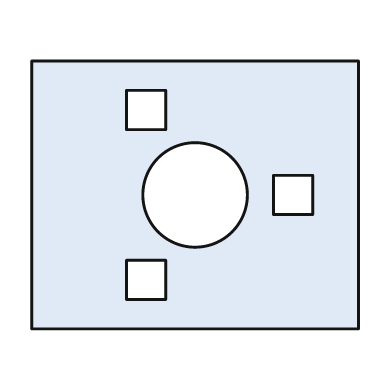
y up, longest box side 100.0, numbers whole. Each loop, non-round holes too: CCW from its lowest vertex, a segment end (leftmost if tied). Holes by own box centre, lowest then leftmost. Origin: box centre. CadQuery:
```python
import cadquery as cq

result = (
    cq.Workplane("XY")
    .moveTo(-50.0, -41.0)
    .lineTo(50.0, -41.0)
    .lineTo(50.0, 41.0)
    .lineTo(-50.0, 41.0)
    .close()
    .moveTo(-21.0, -32.0)
    .lineTo(-9.0, -32.0)
    .lineTo(-9.0, -20.0)
    .lineTo(-21.0, -20.0)
    .close()
    .moveTo(0.0, 0.0)
    .circle(16.0)
    .moveTo(24.0, -6.0)
    .lineTo(36.0, -6.0)
    .lineTo(36.0, 6.0)
    .lineTo(24.0, 6.0)
    .close()
    .moveTo(-21.0, 20.0)
    .lineTo(-9.0, 20.0)
    .lineTo(-9.0, 32.0)
    .lineTo(-21.0, 32.0)
    .close()
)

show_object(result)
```